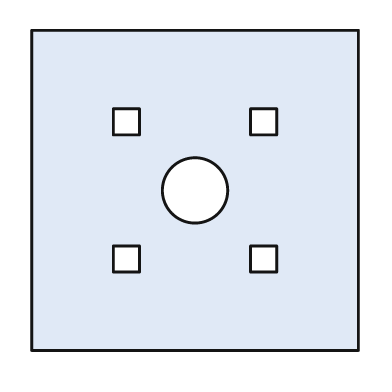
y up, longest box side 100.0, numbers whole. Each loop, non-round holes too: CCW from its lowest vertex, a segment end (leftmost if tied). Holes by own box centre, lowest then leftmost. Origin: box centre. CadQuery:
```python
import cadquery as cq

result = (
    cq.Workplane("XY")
    .moveTo(-50.0, -49.0)
    .lineTo(50.0, -49.0)
    .lineTo(50.0, 49.0)
    .lineTo(-50.0, 49.0)
    .close()
    .moveTo(-25.0, -25.0)
    .lineTo(-17.0, -25.0)
    .lineTo(-17.0, -17.0)
    .lineTo(-25.0, -17.0)
    .close()
    .moveTo(17.0, -25.0)
    .lineTo(25.0, -25.0)
    .lineTo(25.0, -17.0)
    .lineTo(17.0, -17.0)
    .close()
    .moveTo(0.0, 0.0)
    .circle(10.0)
    .moveTo(-25.0, 17.0)
    .lineTo(-17.0, 17.0)
    .lineTo(-17.0, 25.0)
    .lineTo(-25.0, 25.0)
    .close()
    .moveTo(17.0, 17.0)
    .lineTo(25.0, 17.0)
    .lineTo(25.0, 25.0)
    .lineTo(17.0, 25.0)
    .close()
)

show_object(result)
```